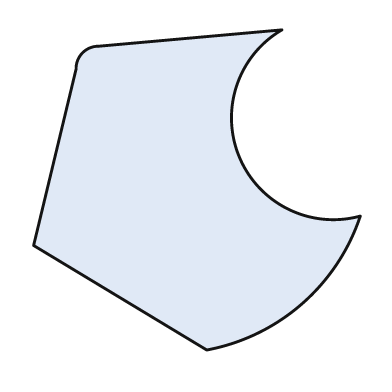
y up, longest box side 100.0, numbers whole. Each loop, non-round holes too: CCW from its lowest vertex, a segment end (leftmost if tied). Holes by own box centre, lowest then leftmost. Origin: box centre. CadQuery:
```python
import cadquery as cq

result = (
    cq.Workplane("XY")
    .moveTo(3.0, -49.0)
    .threePointArc((32.0, -35.0), (50.0, -8.0))
    .threePointArc((13.0, 10.0), (26.0, 49.0))
    .lineTo(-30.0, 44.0)
    .threePointArc((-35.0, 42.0), (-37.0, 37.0))
    .lineTo(-50.0, -17.0)
    .close()
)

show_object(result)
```